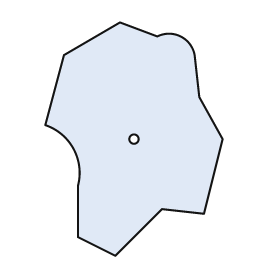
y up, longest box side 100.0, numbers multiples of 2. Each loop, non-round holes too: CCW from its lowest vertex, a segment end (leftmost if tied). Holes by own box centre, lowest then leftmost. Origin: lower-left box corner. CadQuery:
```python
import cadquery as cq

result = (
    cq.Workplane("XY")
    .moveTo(30.0, 0.0)
    .lineTo(50.0, 20.0)
    .lineTo(68.0, 18.0)
    .lineTo(76.0, 50.0)
    .lineTo(66.0, 68.0)
    .lineTo(64.0, 86.0)
    .threePointArc((58.0, 94.0), (48.0, 94.0))
    .lineTo(32.0, 100.0)
    .lineTo(8.0, 86.0)
    .lineTo(0.0, 56.0)
    .threePointArc((12.0, 46.0), (14.0, 30.0))
    .lineTo(14.0, 8.0)
    .close()
    .moveTo(38.0, 50.0)
    .circle(2.0)
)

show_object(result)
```